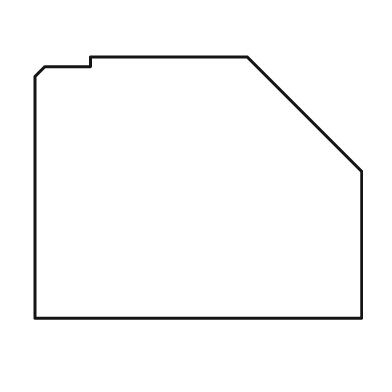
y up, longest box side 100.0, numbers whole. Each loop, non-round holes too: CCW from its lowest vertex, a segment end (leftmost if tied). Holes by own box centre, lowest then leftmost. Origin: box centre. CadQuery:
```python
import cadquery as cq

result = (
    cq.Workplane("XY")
    .moveTo(-50.0, -40.0)
    .lineTo(50.0, -40.0)
    .lineTo(50.0, 5.0)
    .lineTo(15.0, 40.0)
    .lineTo(-33.0, 40.0)
    .lineTo(-33.0, 37.0)
    .lineTo(-47.0, 37.0)
    .lineTo(-50.0, 34.0)
    .close()
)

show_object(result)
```